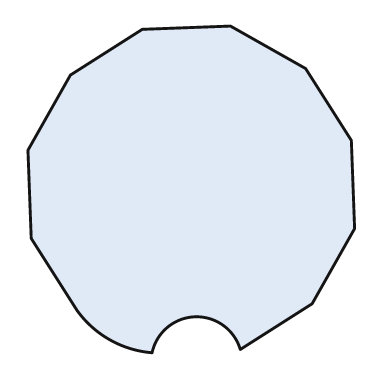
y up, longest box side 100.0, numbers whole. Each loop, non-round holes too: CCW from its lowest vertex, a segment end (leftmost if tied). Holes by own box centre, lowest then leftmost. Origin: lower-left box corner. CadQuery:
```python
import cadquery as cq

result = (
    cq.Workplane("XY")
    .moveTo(38.0, 0.0)
    .threePointArc((51.0, 11.0), (65.0, 1.0))
    .lineTo(87.0, 15.0)
    .lineTo(100.0, 38.0)
    .lineTo(99.0, 65.0)
    .lineTo(85.0, 87.0)
    .lineTo(62.0, 100.0)
    .lineTo(35.0, 99.0)
    .lineTo(13.0, 85.0)
    .lineTo(0.0, 62.0)
    .lineTo(1.0, 35.0)
    .lineTo(15.0, 13.0)
    .threePointArc((25.0, 4.0), (38.0, 0.0))
    .close()
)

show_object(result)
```